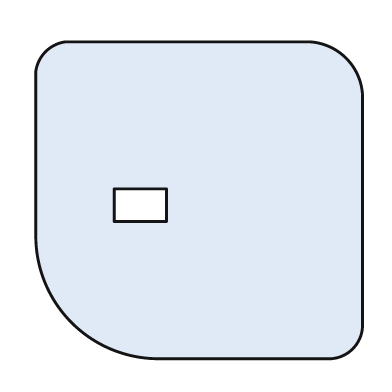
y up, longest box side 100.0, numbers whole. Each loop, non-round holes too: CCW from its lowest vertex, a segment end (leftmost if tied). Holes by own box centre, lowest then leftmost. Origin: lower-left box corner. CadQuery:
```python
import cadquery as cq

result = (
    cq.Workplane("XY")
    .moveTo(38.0, 0.0)
    .lineTo(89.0, 0.0)
    .threePointArc((97.0, 3.0), (100.0, 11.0))
    .lineTo(100.0, 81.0)
    .threePointArc((95.0, 92.0), (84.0, 97.0))
    .lineTo(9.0, 97.0)
    .threePointArc((3.0, 94.0), (0.0, 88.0))
    .lineTo(0.0, 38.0)
    .threePointArc((11.0, 11.0), (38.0, 0.0))
    .close()
    .moveTo(24.0, 42.0)
    .lineTo(40.0, 42.0)
    .lineTo(40.0, 52.0)
    .lineTo(24.0, 52.0)
    .close()
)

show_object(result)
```